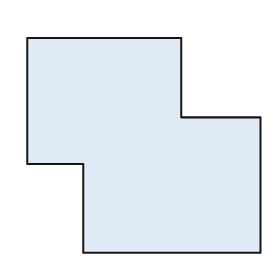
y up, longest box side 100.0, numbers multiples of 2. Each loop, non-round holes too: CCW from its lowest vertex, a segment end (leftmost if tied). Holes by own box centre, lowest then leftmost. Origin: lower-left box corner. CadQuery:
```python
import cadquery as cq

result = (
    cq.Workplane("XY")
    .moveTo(24.0, 0.0)
    .lineTo(100.0, 0.0)
    .lineTo(100.0, 58.0)
    .lineTo(66.0, 58.0)
    .lineTo(66.0, 92.0)
    .lineTo(0.0, 92.0)
    .lineTo(0.0, 38.0)
    .lineTo(24.0, 38.0)
    .close()
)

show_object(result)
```